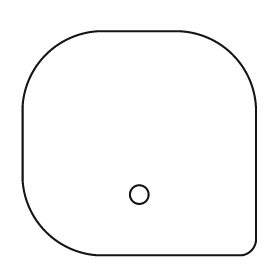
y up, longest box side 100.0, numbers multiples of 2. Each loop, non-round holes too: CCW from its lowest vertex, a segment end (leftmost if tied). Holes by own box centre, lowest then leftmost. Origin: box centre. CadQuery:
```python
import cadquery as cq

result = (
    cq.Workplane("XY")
    .moveTo(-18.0, -48.0)
    .lineTo(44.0, -48.0)
    .threePointArc((48.0, -46.0), (50.0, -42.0))
    .lineTo(50.0, 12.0)
    .threePointArc((40.0, 38.0), (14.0, 48.0))
    .lineTo(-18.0, 48.0)
    .threePointArc((-40.0, 38.0), (-50.0, 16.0))
    .lineTo(-50.0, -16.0)
    .threePointArc((-40.0, -38.0), (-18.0, -48.0))
    .close()
    .moveTo(0.0, -22.0)
    .circle(4.0)
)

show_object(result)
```